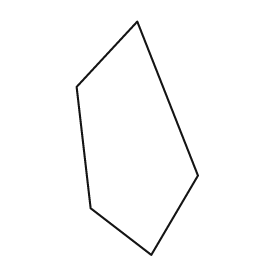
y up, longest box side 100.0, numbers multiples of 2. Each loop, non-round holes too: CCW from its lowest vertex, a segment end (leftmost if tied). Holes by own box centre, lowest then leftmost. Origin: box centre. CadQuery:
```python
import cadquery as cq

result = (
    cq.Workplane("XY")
    .moveTo(6.0, -50.0)
    .lineTo(26.0, -16.0)
    .lineTo(0.0, 50.0)
    .lineTo(-26.0, 22.0)
    .lineTo(-20.0, -30.0)
    .close()
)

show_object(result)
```